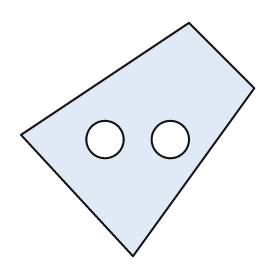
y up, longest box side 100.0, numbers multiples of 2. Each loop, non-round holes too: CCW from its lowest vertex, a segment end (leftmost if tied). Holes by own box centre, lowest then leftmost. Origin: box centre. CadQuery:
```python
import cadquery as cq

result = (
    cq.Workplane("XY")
    .moveTo(-2.0, -50.0)
    .lineTo(50.0, 22.0)
    .lineTo(22.0, 50.0)
    .lineTo(-50.0, 2.0)
    .close()
    .moveTo(-14.0, 0.0)
    .circle(8.0)
    .moveTo(14.0, 0.0)
    .circle(8.0)
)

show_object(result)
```